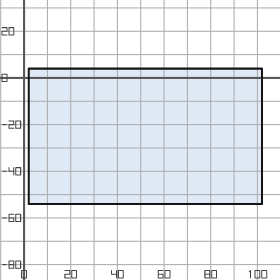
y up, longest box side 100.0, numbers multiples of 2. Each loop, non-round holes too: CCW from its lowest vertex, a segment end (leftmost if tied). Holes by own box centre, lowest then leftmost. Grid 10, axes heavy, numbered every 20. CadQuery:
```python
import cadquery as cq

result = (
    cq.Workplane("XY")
    .moveTo(2.0, -54.0)
    .lineTo(102.0, -54.0)
    .lineTo(102.0, 4.0)
    .lineTo(2.0, 4.0)
    .close()
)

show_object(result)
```